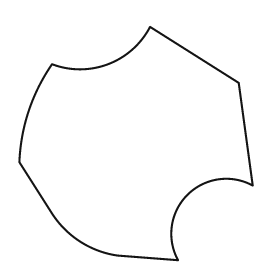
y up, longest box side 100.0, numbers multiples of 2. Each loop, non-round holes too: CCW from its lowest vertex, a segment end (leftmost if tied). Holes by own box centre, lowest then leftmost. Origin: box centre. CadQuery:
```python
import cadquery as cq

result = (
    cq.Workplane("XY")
    .moveTo(18.0, -50.0)
    .threePointArc((22.0, -22.0), (50.0, -18.0))
    .lineTo(44.0, 26.0)
    .lineTo(6.0, 50.0)
    .threePointArc((-12.0, 34.0), (-36.0, 34.0))
    .threePointArc((-46.0, 14.0), (-50.0, -8.0))
    .lineTo(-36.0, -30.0)
    .threePointArc((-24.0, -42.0), (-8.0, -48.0))
    .close()
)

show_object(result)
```